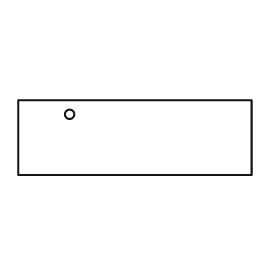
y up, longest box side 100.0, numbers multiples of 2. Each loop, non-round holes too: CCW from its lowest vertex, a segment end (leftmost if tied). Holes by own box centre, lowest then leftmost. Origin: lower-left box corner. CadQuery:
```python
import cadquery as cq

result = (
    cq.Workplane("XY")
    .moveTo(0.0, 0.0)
    .lineTo(100.0, 0.0)
    .lineTo(100.0, 32.0)
    .lineTo(0.0, 32.0)
    .close()
    .moveTo(22.0, 26.0)
    .circle(2.0)
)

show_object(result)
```